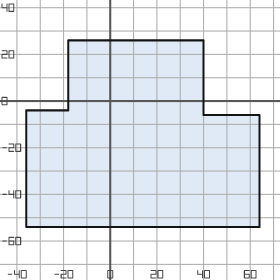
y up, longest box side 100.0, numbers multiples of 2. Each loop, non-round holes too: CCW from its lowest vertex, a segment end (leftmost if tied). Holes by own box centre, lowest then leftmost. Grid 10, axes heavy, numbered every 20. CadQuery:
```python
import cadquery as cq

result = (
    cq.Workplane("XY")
    .moveTo(-36.0, -54.0)
    .lineTo(64.0, -54.0)
    .lineTo(64.0, -6.0)
    .lineTo(40.0, -6.0)
    .lineTo(40.0, 26.0)
    .lineTo(-18.0, 26.0)
    .lineTo(-18.0, -4.0)
    .lineTo(-36.0, -4.0)
    .close()
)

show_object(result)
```